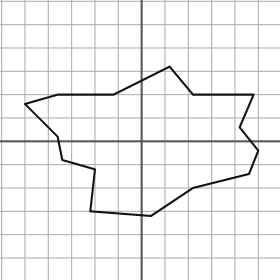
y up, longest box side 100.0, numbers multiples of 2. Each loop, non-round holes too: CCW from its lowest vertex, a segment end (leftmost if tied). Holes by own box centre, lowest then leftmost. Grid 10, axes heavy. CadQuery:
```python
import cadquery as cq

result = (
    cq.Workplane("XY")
    .moveTo(4.0, -32.0)
    .lineTo(22.0, -20.0)
    .lineTo(46.0, -14.0)
    .lineTo(50.0, -4.0)
    .lineTo(42.0, 6.0)
    .lineTo(48.0, 20.0)
    .lineTo(22.0, 20.0)
    .lineTo(12.0, 32.0)
    .lineTo(-12.0, 20.0)
    .lineTo(-36.0, 20.0)
    .lineTo(-50.0, 16.0)
    .lineTo(-36.0, 2.0)
    .lineTo(-34.0, -8.0)
    .lineTo(-20.0, -12.0)
    .lineTo(-22.0, -30.0)
    .close()
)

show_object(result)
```